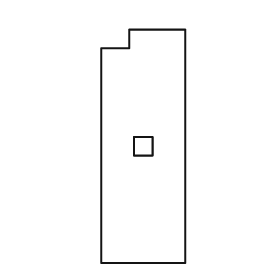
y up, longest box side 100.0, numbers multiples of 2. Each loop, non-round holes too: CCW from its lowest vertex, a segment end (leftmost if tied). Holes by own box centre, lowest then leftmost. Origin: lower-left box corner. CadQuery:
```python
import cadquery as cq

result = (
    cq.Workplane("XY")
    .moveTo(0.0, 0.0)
    .lineTo(36.0, 0.0)
    .lineTo(36.0, 100.0)
    .lineTo(12.0, 100.0)
    .lineTo(12.0, 92.0)
    .lineTo(0.0, 92.0)
    .close()
    .moveTo(14.0, 46.0)
    .lineTo(22.0, 46.0)
    .lineTo(22.0, 54.0)
    .lineTo(14.0, 54.0)
    .close()
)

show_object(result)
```